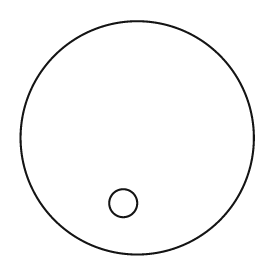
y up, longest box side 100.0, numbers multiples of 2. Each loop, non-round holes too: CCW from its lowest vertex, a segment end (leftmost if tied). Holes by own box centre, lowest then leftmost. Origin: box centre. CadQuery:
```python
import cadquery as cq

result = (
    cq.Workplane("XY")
    .moveTo(0.0, 0.0)
    .circle(50.0)
    .moveTo(-6.0, -28.0)
    .circle(6.0)
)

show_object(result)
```